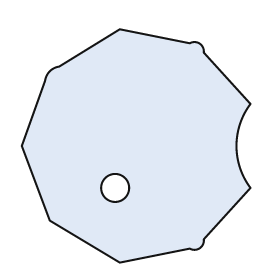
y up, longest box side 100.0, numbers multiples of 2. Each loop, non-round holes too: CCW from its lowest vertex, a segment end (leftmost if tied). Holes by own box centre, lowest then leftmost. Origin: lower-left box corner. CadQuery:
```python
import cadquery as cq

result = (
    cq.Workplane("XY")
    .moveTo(42.0, 0.0)
    .lineTo(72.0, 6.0)
    .threePointArc((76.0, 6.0), (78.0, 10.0))
    .lineTo(98.0, 32.0)
    .threePointArc((92.0, 50.0), (98.0, 68.0))
    .lineTo(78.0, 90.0)
    .threePointArc((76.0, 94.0), (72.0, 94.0))
    .lineTo(42.0, 100.0)
    .lineTo(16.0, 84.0)
    .threePointArc((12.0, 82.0), (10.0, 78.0))
    .lineTo(0.0, 50.0)
    .lineTo(12.0, 18.0)
    .close()
    .moveTo(40.0, 32.0)
    .circle(6.0)
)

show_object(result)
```